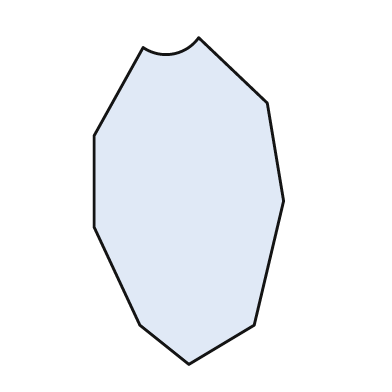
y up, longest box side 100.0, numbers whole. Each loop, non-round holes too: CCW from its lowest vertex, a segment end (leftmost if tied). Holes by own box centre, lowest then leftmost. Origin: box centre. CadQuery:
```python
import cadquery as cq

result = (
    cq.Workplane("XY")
    .moveTo(0.0, -50.0)
    .lineTo(20.0, -38.0)
    .lineTo(29.0, 0.0)
    .lineTo(24.0, 30.0)
    .lineTo(3.0, 50.0)
    .threePointArc((-5.0, 45.0), (-14.0, 47.0))
    .lineTo(-29.0, 20.0)
    .lineTo(-29.0, -8.0)
    .lineTo(-15.0, -38.0)
    .close()
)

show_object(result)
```